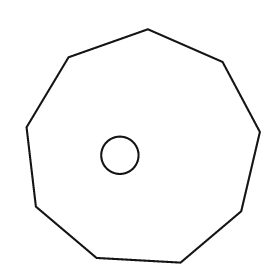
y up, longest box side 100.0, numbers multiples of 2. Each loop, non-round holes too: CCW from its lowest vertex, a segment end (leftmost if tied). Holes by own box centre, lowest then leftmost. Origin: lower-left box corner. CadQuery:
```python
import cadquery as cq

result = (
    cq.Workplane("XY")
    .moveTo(66.0, 0.0)
    .lineTo(92.0, 22.0)
    .lineTo(100.0, 56.0)
    .lineTo(84.0, 86.0)
    .lineTo(52.0, 100.0)
    .lineTo(18.0, 88.0)
    .lineTo(0.0, 58.0)
    .lineTo(4.0, 24.0)
    .lineTo(30.0, 2.0)
    .close()
    .moveTo(40.0, 46.0)
    .circle(8.0)
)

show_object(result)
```